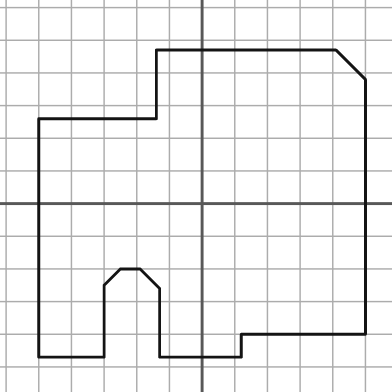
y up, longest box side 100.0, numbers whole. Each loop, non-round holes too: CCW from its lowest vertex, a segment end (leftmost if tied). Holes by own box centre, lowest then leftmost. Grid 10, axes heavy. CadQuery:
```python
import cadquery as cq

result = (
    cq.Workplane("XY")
    .moveTo(-50.0, -47.0)
    .lineTo(-30.0, -47.0)
    .lineTo(-30.0, -25.0)
    .lineTo(-25.0, -20.0)
    .lineTo(-19.0, -20.0)
    .lineTo(-13.0, -26.0)
    .lineTo(-13.0, -47.0)
    .lineTo(12.0, -47.0)
    .lineTo(12.0, -40.0)
    .lineTo(50.0, -40.0)
    .lineTo(50.0, 38.0)
    .lineTo(41.0, 47.0)
    .lineTo(-14.0, 47.0)
    .lineTo(-14.0, 26.0)
    .lineTo(-50.0, 26.0)
    .close()
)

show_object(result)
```